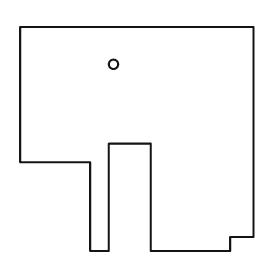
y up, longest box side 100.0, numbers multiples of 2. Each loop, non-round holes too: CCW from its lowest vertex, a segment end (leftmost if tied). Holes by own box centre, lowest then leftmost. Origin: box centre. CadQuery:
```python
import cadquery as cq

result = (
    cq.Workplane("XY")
    .moveTo(-20.0, -48.0)
    .lineTo(-12.0, -48.0)
    .lineTo(-12.0, -2.0)
    .lineTo(6.0, -2.0)
    .lineTo(6.0, -48.0)
    .lineTo(40.0, -48.0)
    .lineTo(40.0, -42.0)
    .lineTo(50.0, -42.0)
    .lineTo(50.0, 48.0)
    .lineTo(-50.0, 48.0)
    .lineTo(-50.0, -10.0)
    .lineTo(-20.0, -10.0)
    .close()
    .moveTo(-10.0, 32.0)
    .circle(2.0)
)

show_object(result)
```